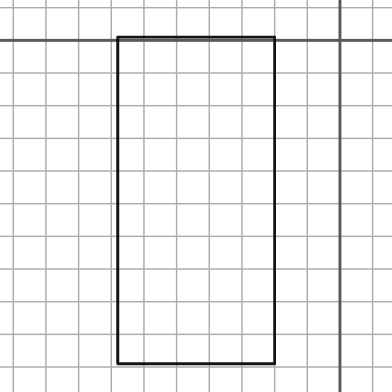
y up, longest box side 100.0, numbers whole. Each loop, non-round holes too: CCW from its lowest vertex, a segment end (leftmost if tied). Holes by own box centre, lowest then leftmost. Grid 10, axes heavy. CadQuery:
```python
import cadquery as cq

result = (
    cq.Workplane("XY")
    .moveTo(-68.0, -99.0)
    .lineTo(-20.0, -99.0)
    .lineTo(-20.0, 1.0)
    .lineTo(-68.0, 1.0)
    .close()
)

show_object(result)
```